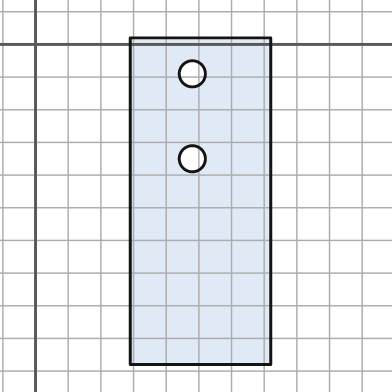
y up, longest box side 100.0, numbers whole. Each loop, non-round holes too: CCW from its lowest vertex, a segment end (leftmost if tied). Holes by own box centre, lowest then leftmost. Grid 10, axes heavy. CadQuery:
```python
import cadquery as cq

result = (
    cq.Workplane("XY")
    .moveTo(29.0, -98.0)
    .lineTo(72.0, -98.0)
    .lineTo(72.0, 2.0)
    .lineTo(29.0, 2.0)
    .close()
    .moveTo(48.0, -35.0)
    .circle(4.0)
    .moveTo(48.0, -9.0)
    .circle(4.0)
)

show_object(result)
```